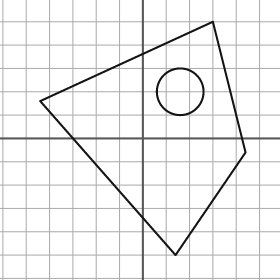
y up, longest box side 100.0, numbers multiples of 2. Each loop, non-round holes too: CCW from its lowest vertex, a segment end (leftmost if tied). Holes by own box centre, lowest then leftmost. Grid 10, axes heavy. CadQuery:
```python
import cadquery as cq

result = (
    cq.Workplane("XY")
    .moveTo(14.0, -50.0)
    .lineTo(44.0, -6.0)
    .lineTo(30.0, 50.0)
    .lineTo(-44.0, 16.0)
    .close()
    .moveTo(16.0, 20.0)
    .circle(10.0)
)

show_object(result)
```